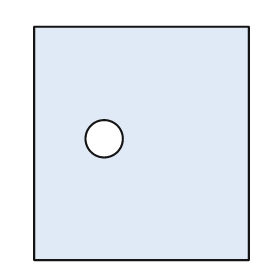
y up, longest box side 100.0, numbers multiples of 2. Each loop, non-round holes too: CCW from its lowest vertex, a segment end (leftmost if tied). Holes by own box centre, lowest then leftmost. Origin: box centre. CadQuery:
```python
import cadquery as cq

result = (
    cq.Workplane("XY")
    .moveTo(-46.0, -50.0)
    .lineTo(46.0, -50.0)
    .lineTo(46.0, 50.0)
    .lineTo(-46.0, 50.0)
    .close()
    .moveTo(-16.0, 2.0)
    .circle(8.0)
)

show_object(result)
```